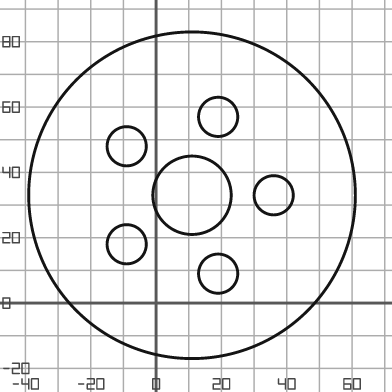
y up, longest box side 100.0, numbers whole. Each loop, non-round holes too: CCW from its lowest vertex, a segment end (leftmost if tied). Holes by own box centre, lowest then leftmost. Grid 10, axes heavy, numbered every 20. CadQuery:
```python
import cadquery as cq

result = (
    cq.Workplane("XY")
    .moveTo(11.0, 33.0)
    .circle(50.0)
    .moveTo(19.0, 9.0)
    .circle(6.0)
    .moveTo(-9.0, 18.0)
    .circle(6.0)
    .moveTo(11.0, 33.0)
    .circle(12.0)
    .moveTo(36.0, 33.0)
    .circle(6.0)
    .moveTo(-9.0, 48.0)
    .circle(6.0)
    .moveTo(19.0, 57.0)
    .circle(6.0)
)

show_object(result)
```